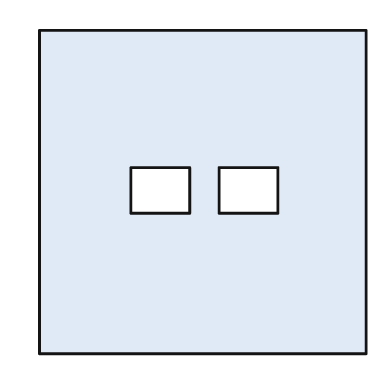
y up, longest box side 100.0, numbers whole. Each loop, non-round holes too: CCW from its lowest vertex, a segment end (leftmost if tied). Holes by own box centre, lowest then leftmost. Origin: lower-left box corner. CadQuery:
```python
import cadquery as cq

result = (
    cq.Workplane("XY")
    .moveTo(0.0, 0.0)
    .lineTo(100.0, 0.0)
    .lineTo(100.0, 99.0)
    .lineTo(0.0, 99.0)
    .close()
    .moveTo(28.0, 43.0)
    .lineTo(46.0, 43.0)
    .lineTo(46.0, 57.0)
    .lineTo(28.0, 57.0)
    .close()
    .moveTo(55.0, 43.0)
    .lineTo(73.0, 43.0)
    .lineTo(73.0, 57.0)
    .lineTo(55.0, 57.0)
    .close()
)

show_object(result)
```